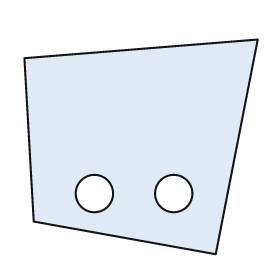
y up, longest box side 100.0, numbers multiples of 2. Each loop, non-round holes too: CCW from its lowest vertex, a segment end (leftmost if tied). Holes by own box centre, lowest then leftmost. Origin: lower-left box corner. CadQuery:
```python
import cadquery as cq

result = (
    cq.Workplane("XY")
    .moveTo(82.0, 0.0)
    .lineTo(100.0, 92.0)
    .lineTo(0.0, 84.0)
    .lineTo(4.0, 14.0)
    .close()
    .moveTo(30.0, 26.0)
    .circle(8.0)
    .moveTo(64.0, 26.0)
    .circle(8.0)
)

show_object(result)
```